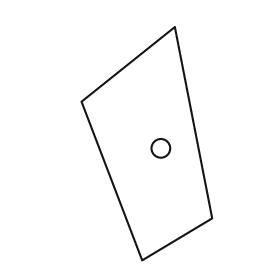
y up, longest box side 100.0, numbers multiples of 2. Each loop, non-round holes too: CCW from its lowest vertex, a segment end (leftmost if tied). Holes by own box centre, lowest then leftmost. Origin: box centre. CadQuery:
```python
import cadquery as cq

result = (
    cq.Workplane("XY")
    .moveTo(-2.0, -50.0)
    .lineTo(28.0, -32.0)
    .lineTo(12.0, 50.0)
    .lineTo(-28.0, 18.0)
    .close()
    .moveTo(6.0, -2.0)
    .circle(4.0)
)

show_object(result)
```